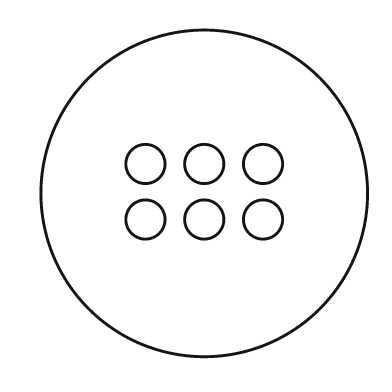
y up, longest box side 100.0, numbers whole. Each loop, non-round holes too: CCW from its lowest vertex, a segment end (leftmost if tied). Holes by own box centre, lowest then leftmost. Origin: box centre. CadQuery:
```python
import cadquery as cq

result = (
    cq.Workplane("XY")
    .moveTo(0.0, 0.0)
    .circle(50.0)
    .moveTo(-18.0, -8.0)
    .circle(6.0)
    .moveTo(0.0, -8.0)
    .circle(6.0)
    .moveTo(18.0, -8.0)
    .circle(6.0)
    .moveTo(-18.0, 9.0)
    .circle(6.0)
    .moveTo(0.0, 9.0)
    .circle(6.0)
    .moveTo(18.0, 9.0)
    .circle(6.0)
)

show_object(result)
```